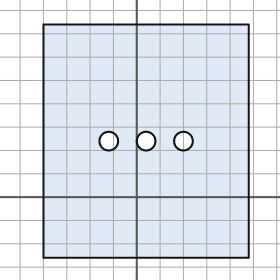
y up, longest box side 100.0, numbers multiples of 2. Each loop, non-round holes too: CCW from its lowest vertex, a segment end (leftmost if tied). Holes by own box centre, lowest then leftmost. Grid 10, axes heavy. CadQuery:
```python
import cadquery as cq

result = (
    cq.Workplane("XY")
    .moveTo(-40.0, -26.0)
    .lineTo(48.0, -26.0)
    .lineTo(48.0, 74.0)
    .lineTo(-40.0, 74.0)
    .close()
    .moveTo(-12.0, 24.0)
    .circle(4.0)
    .moveTo(4.0, 24.0)
    .circle(4.0)
    .moveTo(20.0, 24.0)
    .circle(4.0)
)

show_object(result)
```